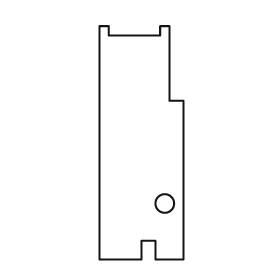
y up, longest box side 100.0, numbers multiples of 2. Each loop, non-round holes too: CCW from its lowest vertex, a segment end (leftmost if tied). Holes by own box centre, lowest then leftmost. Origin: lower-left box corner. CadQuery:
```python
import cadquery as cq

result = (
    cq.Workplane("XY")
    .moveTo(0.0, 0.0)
    .lineTo(18.0, 0.0)
    .lineTo(18.0, 8.0)
    .lineTo(24.0, 8.0)
    .lineTo(24.0, 0.0)
    .lineTo(36.0, 0.0)
    .lineTo(36.0, 68.0)
    .lineTo(30.0, 68.0)
    .lineTo(30.0, 100.0)
    .lineTo(26.0, 100.0)
    .lineTo(26.0, 96.0)
    .lineTo(4.0, 96.0)
    .lineTo(4.0, 100.0)
    .lineTo(0.0, 100.0)
    .close()
    .moveTo(28.0, 24.0)
    .circle(4.0)
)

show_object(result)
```